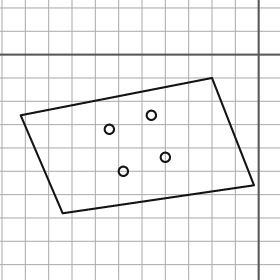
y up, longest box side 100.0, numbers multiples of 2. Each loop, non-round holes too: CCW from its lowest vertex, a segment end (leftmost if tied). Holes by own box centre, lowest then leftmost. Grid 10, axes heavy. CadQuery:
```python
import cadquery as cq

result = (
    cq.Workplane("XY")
    .moveTo(-84.0, -68.0)
    .lineTo(-2.0, -56.0)
    .lineTo(-20.0, -10.0)
    .lineTo(-102.0, -26.0)
    .close()
    .moveTo(-58.0, -50.0)
    .circle(2.0)
    .moveTo(-40.0, -44.0)
    .circle(2.0)
    .moveTo(-64.0, -32.0)
    .circle(2.0)
    .moveTo(-46.0, -26.0)
    .circle(2.0)
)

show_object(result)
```